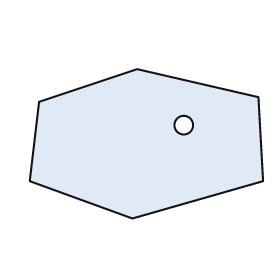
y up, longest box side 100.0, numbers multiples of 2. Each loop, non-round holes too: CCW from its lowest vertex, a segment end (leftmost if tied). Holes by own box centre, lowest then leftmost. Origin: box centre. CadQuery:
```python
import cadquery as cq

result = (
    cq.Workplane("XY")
    .moveTo(-6.0, -32.0)
    .lineTo(50.0, -16.0)
    .lineTo(48.0, 20.0)
    .lineTo(-4.0, 32.0)
    .lineTo(-46.0, 18.0)
    .lineTo(-50.0, -16.0)
    .close()
    .moveTo(16.0, 8.0)
    .circle(4.0)
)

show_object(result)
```